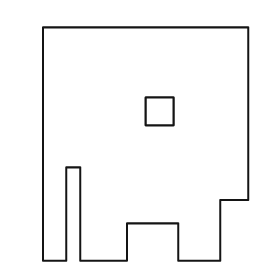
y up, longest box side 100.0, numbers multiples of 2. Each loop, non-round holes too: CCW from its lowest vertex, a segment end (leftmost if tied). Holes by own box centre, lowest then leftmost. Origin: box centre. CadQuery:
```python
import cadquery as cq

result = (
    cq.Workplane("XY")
    .moveTo(-44.0, -50.0)
    .lineTo(-34.0, -50.0)
    .lineTo(-34.0, -10.0)
    .lineTo(-28.0, -10.0)
    .lineTo(-28.0, -50.0)
    .lineTo(-8.0, -50.0)
    .lineTo(-8.0, -34.0)
    .lineTo(14.0, -34.0)
    .lineTo(14.0, -50.0)
    .lineTo(32.0, -50.0)
    .lineTo(32.0, -24.0)
    .lineTo(44.0, -24.0)
    .lineTo(44.0, 50.0)
    .lineTo(-44.0, 50.0)
    .close()
    .moveTo(0.0, 8.0)
    .lineTo(12.0, 8.0)
    .lineTo(12.0, 20.0)
    .lineTo(0.0, 20.0)
    .close()
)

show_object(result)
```